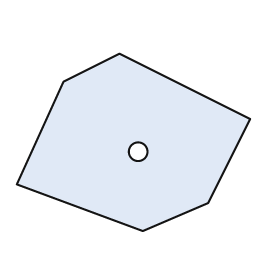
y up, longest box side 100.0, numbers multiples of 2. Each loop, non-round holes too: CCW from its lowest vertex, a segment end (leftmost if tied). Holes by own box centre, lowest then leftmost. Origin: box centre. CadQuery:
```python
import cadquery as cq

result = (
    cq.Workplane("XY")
    .moveTo(4.0, -38.0)
    .lineTo(32.0, -26.0)
    .lineTo(50.0, 10.0)
    .lineTo(-6.0, 38.0)
    .lineTo(-30.0, 26.0)
    .lineTo(-50.0, -18.0)
    .close()
    .moveTo(2.0, -4.0)
    .circle(4.0)
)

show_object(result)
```